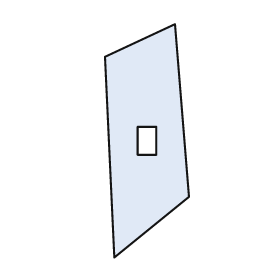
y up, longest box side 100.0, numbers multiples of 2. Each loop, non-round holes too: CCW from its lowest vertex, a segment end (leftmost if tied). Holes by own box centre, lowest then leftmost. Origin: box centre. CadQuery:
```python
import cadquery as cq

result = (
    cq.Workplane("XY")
    .moveTo(-14.0, -50.0)
    .lineTo(18.0, -24.0)
    .lineTo(12.0, 50.0)
    .lineTo(-18.0, 36.0)
    .close()
    .moveTo(-4.0, -6.0)
    .lineTo(4.0, -6.0)
    .lineTo(4.0, 6.0)
    .lineTo(-4.0, 6.0)
    .close()
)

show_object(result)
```